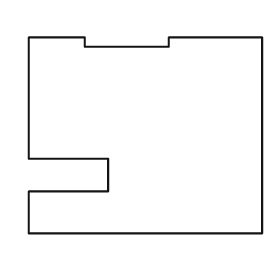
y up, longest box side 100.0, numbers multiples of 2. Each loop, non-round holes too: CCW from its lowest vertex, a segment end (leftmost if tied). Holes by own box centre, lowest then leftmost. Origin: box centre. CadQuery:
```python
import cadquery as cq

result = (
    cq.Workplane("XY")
    .moveTo(-50.0, -42.0)
    .lineTo(50.0, -42.0)
    .lineTo(50.0, 42.0)
    .lineTo(10.0, 42.0)
    .lineTo(10.0, 38.0)
    .lineTo(-26.0, 38.0)
    .lineTo(-26.0, 42.0)
    .lineTo(-50.0, 42.0)
    .lineTo(-50.0, -10.0)
    .lineTo(-16.0, -10.0)
    .lineTo(-16.0, -24.0)
    .lineTo(-50.0, -24.0)
    .close()
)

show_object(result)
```